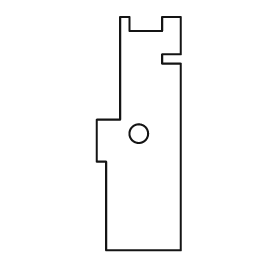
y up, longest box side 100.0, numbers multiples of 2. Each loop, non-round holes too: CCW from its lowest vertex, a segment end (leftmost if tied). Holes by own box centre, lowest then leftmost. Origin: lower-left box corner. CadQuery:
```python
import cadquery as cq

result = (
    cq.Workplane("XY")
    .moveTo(4.0, 0.0)
    .lineTo(36.0, 0.0)
    .lineTo(36.0, 80.0)
    .lineTo(28.0, 80.0)
    .lineTo(28.0, 84.0)
    .lineTo(36.0, 84.0)
    .lineTo(36.0, 100.0)
    .lineTo(28.0, 100.0)
    .lineTo(28.0, 94.0)
    .lineTo(14.0, 94.0)
    .lineTo(14.0, 100.0)
    .lineTo(10.0, 100.0)
    .lineTo(10.0, 56.0)
    .lineTo(0.0, 56.0)
    .lineTo(0.0, 38.0)
    .lineTo(4.0, 38.0)
    .close()
    .moveTo(18.0, 50.0)
    .circle(4.0)
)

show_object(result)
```